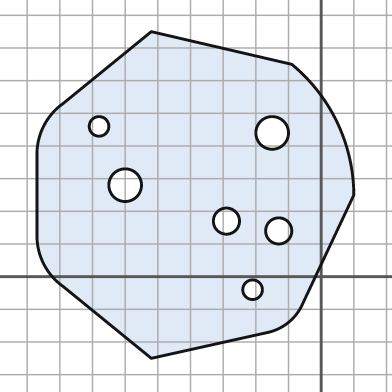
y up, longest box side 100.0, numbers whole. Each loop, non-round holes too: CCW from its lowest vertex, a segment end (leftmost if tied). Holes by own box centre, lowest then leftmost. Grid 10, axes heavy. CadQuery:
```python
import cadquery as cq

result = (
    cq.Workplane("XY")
    .moveTo(-52.0, -25.0)
    .lineTo(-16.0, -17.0)
    .threePointArc((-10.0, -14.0), (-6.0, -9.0))
    .lineTo(10.0, 25.0)
    .threePointArc((5.0, 47.0), (-9.0, 65.0))
    .lineTo(-52.0, 75.0)
    .lineTo(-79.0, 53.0)
    .threePointArc((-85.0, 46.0), (-87.0, 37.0))
    .lineTo(-87.0, 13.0)
    .threePointArc((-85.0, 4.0), (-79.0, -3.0))
    .close()
    .moveTo(-21.0, -4.0)
    .circle(3.0)
    .moveTo(-13.0, 14.0)
    .circle(4.0)
    .moveTo(-29.0, 17.0)
    .circle(4.0)
    .moveTo(-60.0, 28.0)
    .circle(5.0)
    .moveTo(-15.0, 44.0)
    .circle(5.0)
    .moveTo(-68.0, 46.0)
    .circle(3.0)
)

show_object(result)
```